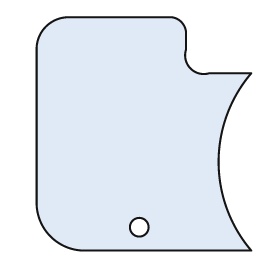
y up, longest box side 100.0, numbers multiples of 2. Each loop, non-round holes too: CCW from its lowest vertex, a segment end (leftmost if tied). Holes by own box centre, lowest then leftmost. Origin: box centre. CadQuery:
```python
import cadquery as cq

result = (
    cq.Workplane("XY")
    .moveTo(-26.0, -50.0)
    .lineTo(46.0, -50.0)
    .threePointArc((32.0, -12.0), (46.0, 26.0))
    .lineTo(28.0, 26.0)
    .threePointArc((20.0, 28.0), (18.0, 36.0))
    .lineTo(18.0, 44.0)
    .threePointArc((16.0, 48.0), (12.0, 50.0))
    .lineTo(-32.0, 50.0)
    .threePointArc((-42.0, 46.0), (-46.0, 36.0))
    .lineTo(-46.0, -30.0)
    .threePointArc((-40.0, -44.0), (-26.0, -50.0))
    .close()
    .moveTo(-2.0, -40.0)
    .circle(4.0)
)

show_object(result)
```